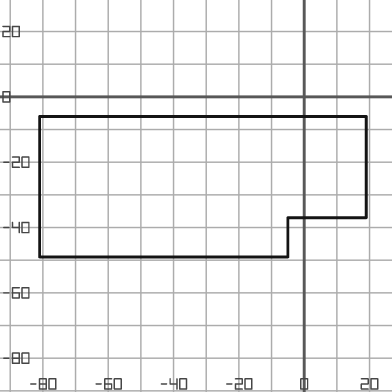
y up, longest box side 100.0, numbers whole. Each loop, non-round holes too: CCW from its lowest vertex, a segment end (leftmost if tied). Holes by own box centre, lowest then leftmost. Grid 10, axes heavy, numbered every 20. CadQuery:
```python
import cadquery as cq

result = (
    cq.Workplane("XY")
    .moveTo(-81.0, -49.0)
    .lineTo(-5.0, -49.0)
    .lineTo(-5.0, -37.0)
    .lineTo(19.0, -37.0)
    .lineTo(19.0, -6.0)
    .lineTo(-81.0, -6.0)
    .close()
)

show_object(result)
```